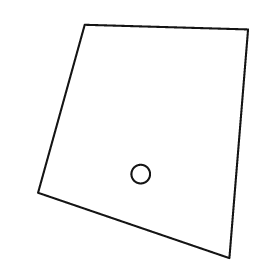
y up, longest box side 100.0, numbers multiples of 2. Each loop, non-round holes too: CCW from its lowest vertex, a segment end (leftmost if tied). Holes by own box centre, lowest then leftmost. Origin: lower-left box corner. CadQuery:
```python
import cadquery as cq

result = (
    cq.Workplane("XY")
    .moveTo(82.0, 0.0)
    .lineTo(90.0, 98.0)
    .lineTo(20.0, 100.0)
    .lineTo(0.0, 28.0)
    .close()
    .moveTo(44.0, 36.0)
    .circle(4.0)
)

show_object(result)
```